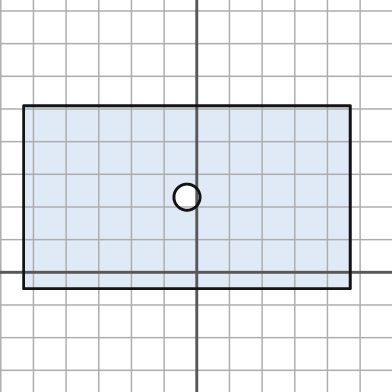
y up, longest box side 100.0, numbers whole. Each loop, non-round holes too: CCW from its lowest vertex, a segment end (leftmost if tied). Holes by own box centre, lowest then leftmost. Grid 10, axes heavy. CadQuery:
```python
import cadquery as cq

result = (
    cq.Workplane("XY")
    .moveTo(-53.0, -5.0)
    .lineTo(47.0, -5.0)
    .lineTo(47.0, 51.0)
    .lineTo(-53.0, 51.0)
    .close()
    .moveTo(-3.0, 23.0)
    .circle(4.0)
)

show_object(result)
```